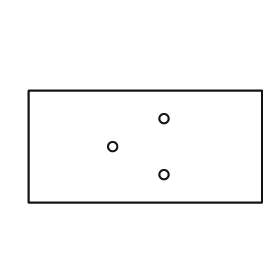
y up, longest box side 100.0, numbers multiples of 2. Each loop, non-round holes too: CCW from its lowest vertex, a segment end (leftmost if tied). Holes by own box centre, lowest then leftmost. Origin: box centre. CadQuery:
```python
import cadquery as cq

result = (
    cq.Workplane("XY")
    .moveTo(-50.0, -24.0)
    .lineTo(50.0, -24.0)
    .lineTo(50.0, 24.0)
    .lineTo(-50.0, 24.0)
    .close()
    .moveTo(8.0, -12.0)
    .circle(2.0)
    .moveTo(-14.0, 0.0)
    .circle(2.0)
    .moveTo(8.0, 12.0)
    .circle(2.0)
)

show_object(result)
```